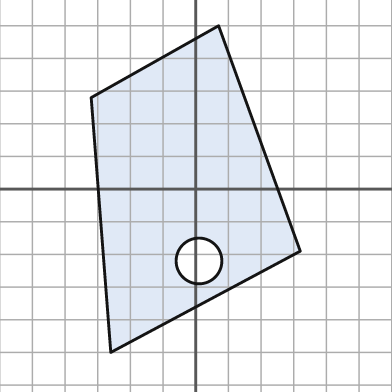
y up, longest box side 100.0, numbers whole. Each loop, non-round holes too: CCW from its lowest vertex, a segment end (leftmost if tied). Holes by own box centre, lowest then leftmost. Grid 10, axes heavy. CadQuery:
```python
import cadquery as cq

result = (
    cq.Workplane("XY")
    .moveTo(-26.0, -50.0)
    .lineTo(32.0, -19.0)
    .lineTo(7.0, 50.0)
    .lineTo(-32.0, 28.0)
    .close()
    .moveTo(1.0, -22.0)
    .circle(7.0)
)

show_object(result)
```